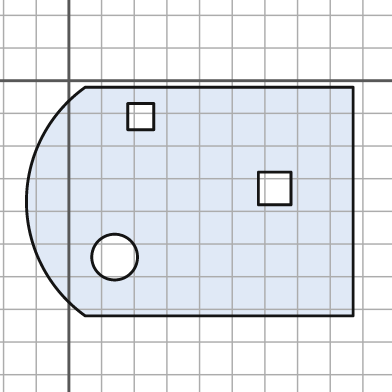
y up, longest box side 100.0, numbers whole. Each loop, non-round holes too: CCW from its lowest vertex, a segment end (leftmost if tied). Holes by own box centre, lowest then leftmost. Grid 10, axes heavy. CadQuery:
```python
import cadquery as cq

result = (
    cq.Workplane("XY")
    .moveTo(5.0, -72.0)
    .lineTo(87.0, -72.0)
    .lineTo(87.0, -2.0)
    .lineTo(5.0, -2.0)
    .threePointArc((-13.0, -37.0), (5.0, -72.0))
    .close()
    .moveTo(14.0, -54.0)
    .circle(7.0)
    .moveTo(58.0, -38.0)
    .lineTo(68.0, -38.0)
    .lineTo(68.0, -28.0)
    .lineTo(58.0, -28.0)
    .close()
    .moveTo(18.0, -15.0)
    .lineTo(26.0, -15.0)
    .lineTo(26.0, -7.0)
    .lineTo(18.0, -7.0)
    .close()
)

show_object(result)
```